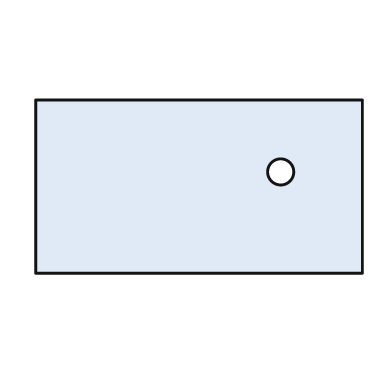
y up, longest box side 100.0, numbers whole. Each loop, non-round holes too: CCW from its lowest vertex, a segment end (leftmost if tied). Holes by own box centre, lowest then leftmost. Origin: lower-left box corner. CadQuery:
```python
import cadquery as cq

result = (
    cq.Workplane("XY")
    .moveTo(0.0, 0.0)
    .lineTo(100.0, 0.0)
    .lineTo(100.0, 53.0)
    .lineTo(0.0, 53.0)
    .close()
    .moveTo(75.0, 31.0)
    .circle(4.0)
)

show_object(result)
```